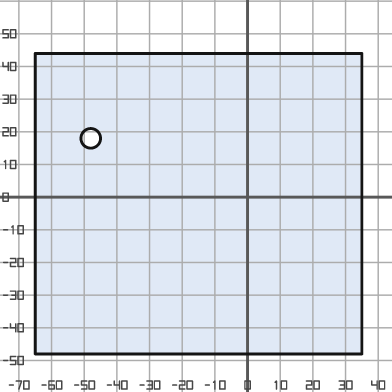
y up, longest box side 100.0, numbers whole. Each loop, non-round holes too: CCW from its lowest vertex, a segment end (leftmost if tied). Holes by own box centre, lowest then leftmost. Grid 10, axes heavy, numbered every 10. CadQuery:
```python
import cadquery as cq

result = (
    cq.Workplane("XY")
    .moveTo(-65.0, -48.0)
    .lineTo(35.0, -48.0)
    .lineTo(35.0, 44.0)
    .lineTo(-65.0, 44.0)
    .close()
    .moveTo(-48.0, 18.0)
    .circle(3.0)
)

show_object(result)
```